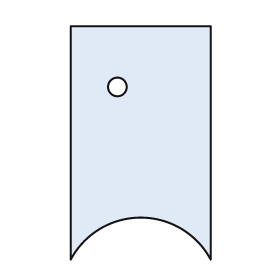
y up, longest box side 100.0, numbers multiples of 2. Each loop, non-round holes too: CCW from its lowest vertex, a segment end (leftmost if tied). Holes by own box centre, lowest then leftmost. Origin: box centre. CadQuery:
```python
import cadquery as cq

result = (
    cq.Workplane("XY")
    .moveTo(-30.0, -50.0)
    .threePointArc((0.0, -32.0), (30.0, -50.0))
    .lineTo(30.0, 50.0)
    .lineTo(-30.0, 50.0)
    .close()
    .moveTo(-10.0, 24.0)
    .circle(4.0)
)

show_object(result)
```